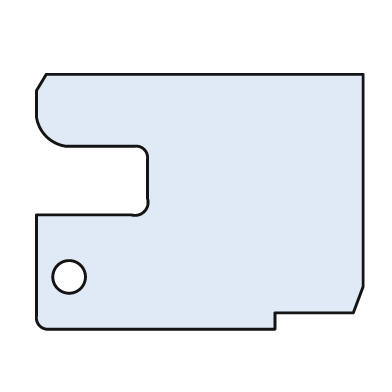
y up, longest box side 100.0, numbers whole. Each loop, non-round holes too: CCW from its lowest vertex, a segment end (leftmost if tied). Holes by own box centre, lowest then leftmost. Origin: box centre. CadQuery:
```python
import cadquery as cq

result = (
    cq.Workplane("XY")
    .moveTo(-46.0, -39.0)
    .lineTo(23.0, -39.0)
    .lineTo(23.0, -34.0)
    .lineTo(47.0, -34.0)
    .lineTo(50.0, -26.0)
    .lineTo(50.0, 39.0)
    .lineTo(-47.0, 39.0)
    .lineTo(-50.0, 34.0)
    .lineTo(-50.0, 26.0)
    .threePointArc((-47.0, 20.0), (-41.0, 17.0))
    .lineTo(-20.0, 17.0)
    .threePointArc((-17.0, 16.0), (-16.0, 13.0))
    .lineTo(-16.0, 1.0)
    .threePointArc((-17.0, -3.0), (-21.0, -4.0))
    .lineTo(-50.0, -4.0)
    .lineTo(-50.0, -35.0)
    .threePointArc((-49.0, -38.0), (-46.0, -39.0))
    .close()
    .moveTo(-40.0, -23.0)
    .circle(5.0)
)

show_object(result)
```